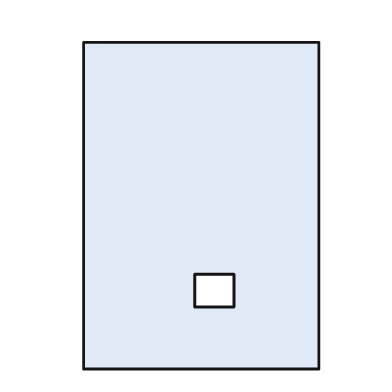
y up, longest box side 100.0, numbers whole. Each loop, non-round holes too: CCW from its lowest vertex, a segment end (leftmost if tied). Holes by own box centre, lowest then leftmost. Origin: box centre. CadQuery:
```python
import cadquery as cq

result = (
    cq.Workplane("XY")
    .moveTo(-36.0, -50.0)
    .lineTo(36.0, -50.0)
    .lineTo(36.0, 50.0)
    .lineTo(-36.0, 50.0)
    .close()
    .moveTo(-2.0, -31.0)
    .lineTo(10.0, -31.0)
    .lineTo(10.0, -21.0)
    .lineTo(-2.0, -21.0)
    .close()
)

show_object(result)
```